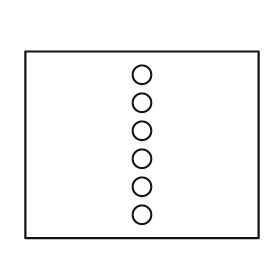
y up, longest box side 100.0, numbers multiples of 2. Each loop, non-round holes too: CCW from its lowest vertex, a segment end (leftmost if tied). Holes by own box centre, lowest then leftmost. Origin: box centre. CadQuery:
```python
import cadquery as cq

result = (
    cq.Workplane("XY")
    .moveTo(-50.0, -40.0)
    .lineTo(50.0, -40.0)
    .lineTo(50.0, 40.0)
    .lineTo(-50.0, 40.0)
    .close()
    .moveTo(0.0, -30.0)
    .circle(4.0)
    .moveTo(0.0, -18.0)
    .circle(4.0)
    .moveTo(0.0, -6.0)
    .circle(4.0)
    .moveTo(0.0, 6.0)
    .circle(4.0)
    .moveTo(0.0, 18.0)
    .circle(4.0)
    .moveTo(0.0, 30.0)
    .circle(4.0)
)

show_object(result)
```